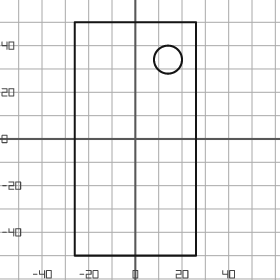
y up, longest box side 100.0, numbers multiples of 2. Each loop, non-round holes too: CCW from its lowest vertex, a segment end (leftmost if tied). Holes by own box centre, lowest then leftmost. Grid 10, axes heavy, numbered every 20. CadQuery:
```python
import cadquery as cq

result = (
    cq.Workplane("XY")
    .moveTo(-26.0, -50.0)
    .lineTo(26.0, -50.0)
    .lineTo(26.0, 50.0)
    .lineTo(-26.0, 50.0)
    .close()
    .moveTo(14.0, 34.0)
    .circle(6.0)
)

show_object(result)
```